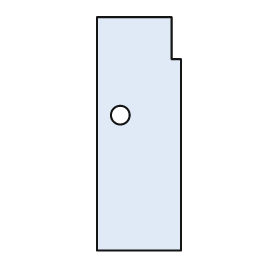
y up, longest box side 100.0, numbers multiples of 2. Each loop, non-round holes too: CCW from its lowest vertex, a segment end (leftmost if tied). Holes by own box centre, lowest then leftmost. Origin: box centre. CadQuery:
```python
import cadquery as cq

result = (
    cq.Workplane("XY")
    .moveTo(-18.0, -50.0)
    .lineTo(18.0, -50.0)
    .lineTo(18.0, 32.0)
    .lineTo(14.0, 32.0)
    .lineTo(14.0, 50.0)
    .lineTo(-18.0, 50.0)
    .close()
    .moveTo(-8.0, 8.0)
    .circle(4.0)
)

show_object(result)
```